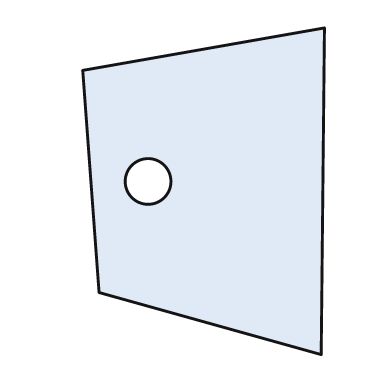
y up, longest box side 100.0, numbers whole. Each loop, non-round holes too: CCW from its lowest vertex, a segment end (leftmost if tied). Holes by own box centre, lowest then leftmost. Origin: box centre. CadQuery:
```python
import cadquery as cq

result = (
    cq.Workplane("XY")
    .moveTo(36.0, -50.0)
    .lineTo(37.0, 50.0)
    .lineTo(-37.0, 37.0)
    .lineTo(-32.0, -31.0)
    .close()
    .moveTo(-17.0, 3.0)
    .circle(7.0)
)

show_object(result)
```